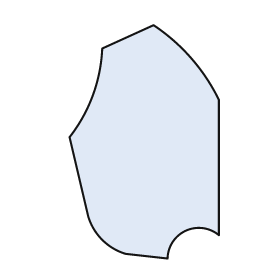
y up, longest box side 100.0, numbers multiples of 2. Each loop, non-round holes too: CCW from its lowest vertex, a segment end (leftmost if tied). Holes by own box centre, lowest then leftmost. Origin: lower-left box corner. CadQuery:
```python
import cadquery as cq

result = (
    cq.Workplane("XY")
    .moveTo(42.0, 0.0)
    .threePointArc((50.0, 12.0), (64.0, 10.0))
    .lineTo(64.0, 68.0)
    .threePointArc((52.0, 86.0), (36.0, 100.0))
    .lineTo(14.0, 90.0)
    .threePointArc((10.0, 70.0), (0.0, 52.0))
    .lineTo(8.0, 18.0)
    .threePointArc((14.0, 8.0), (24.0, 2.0))
    .close()
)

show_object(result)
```